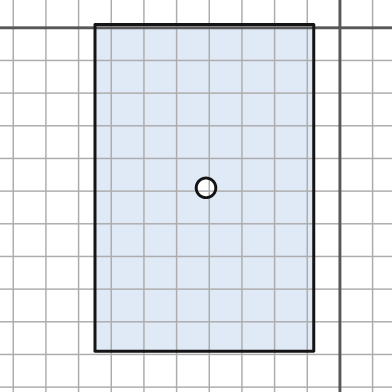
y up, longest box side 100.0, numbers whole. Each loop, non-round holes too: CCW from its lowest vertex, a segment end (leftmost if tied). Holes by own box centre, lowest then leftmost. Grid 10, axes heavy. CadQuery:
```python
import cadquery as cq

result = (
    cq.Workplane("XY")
    .moveTo(-75.0, -99.0)
    .lineTo(-8.0, -99.0)
    .lineTo(-8.0, 1.0)
    .lineTo(-75.0, 1.0)
    .close()
    .moveTo(-41.0, -49.0)
    .circle(3.0)
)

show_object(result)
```